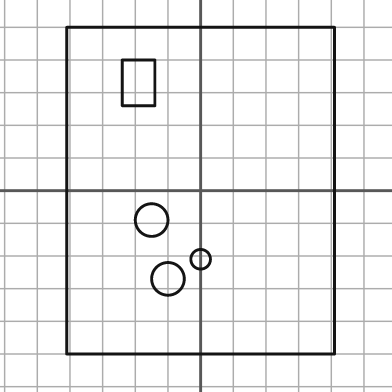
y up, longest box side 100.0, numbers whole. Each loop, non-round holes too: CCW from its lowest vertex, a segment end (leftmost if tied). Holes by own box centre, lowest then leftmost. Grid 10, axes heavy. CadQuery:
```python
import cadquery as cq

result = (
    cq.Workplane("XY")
    .moveTo(-41.0, -50.0)
    .lineTo(41.0, -50.0)
    .lineTo(41.0, 50.0)
    .lineTo(-41.0, 50.0)
    .close()
    .moveTo(-10.0, -27.0)
    .circle(5.0)
    .moveTo(0.0, -21.0)
    .circle(3.0)
    .moveTo(-15.0, -9.0)
    .circle(5.0)
    .moveTo(-24.0, 26.0)
    .lineTo(-14.0, 26.0)
    .lineTo(-14.0, 40.0)
    .lineTo(-24.0, 40.0)
    .close()
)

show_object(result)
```